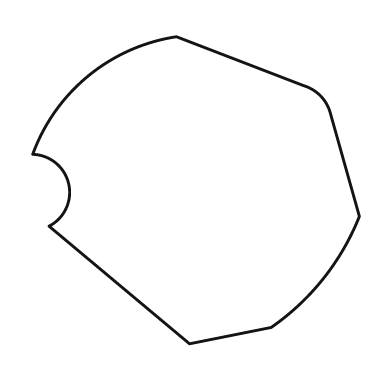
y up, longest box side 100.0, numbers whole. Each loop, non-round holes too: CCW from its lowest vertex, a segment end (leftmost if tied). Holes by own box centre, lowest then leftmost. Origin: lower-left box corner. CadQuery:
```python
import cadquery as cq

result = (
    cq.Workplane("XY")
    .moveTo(48.0, 0.0)
    .lineTo(73.0, 5.0)
    .threePointArc((89.0, 20.0), (100.0, 39.0))
    .lineTo(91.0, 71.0)
    .threePointArc((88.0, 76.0), (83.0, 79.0))
    .lineTo(44.0, 94.0)
    .threePointArc((17.0, 82.0), (0.0, 58.0))
    .threePointArc((11.0, 49.0), (5.0, 36.0))
    .close()
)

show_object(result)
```